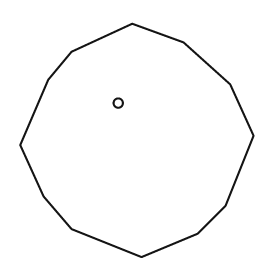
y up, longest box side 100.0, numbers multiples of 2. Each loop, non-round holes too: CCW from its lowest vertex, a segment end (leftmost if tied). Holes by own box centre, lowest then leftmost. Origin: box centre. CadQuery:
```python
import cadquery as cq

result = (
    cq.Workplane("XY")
    .moveTo(2.0, -50.0)
    .lineTo(26.0, -40.0)
    .lineTo(38.0, -28.0)
    .lineTo(50.0, 2.0)
    .lineTo(40.0, 24.0)
    .lineTo(20.0, 42.0)
    .lineTo(-2.0, 50.0)
    .lineTo(-28.0, 38.0)
    .lineTo(-38.0, 26.0)
    .lineTo(-50.0, -2.0)
    .lineTo(-40.0, -24.0)
    .lineTo(-28.0, -38.0)
    .close()
    .moveTo(-8.0, 16.0)
    .circle(2.0)
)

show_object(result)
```